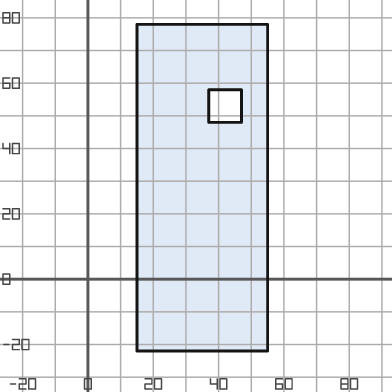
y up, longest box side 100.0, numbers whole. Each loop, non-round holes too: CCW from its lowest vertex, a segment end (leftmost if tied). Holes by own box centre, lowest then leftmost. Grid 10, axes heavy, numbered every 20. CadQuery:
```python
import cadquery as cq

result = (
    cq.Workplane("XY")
    .moveTo(15.0, -22.0)
    .lineTo(55.0, -22.0)
    .lineTo(55.0, 78.0)
    .lineTo(15.0, 78.0)
    .close()
    .moveTo(37.0, 48.0)
    .lineTo(47.0, 48.0)
    .lineTo(47.0, 58.0)
    .lineTo(37.0, 58.0)
    .close()
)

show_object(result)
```